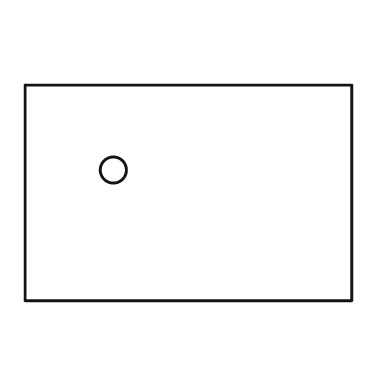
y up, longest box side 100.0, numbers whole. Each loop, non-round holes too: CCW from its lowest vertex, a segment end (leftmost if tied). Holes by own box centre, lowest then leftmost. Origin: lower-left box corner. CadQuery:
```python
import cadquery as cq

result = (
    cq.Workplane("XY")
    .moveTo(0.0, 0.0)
    .lineTo(100.0, 0.0)
    .lineTo(100.0, 66.0)
    .lineTo(0.0, 66.0)
    .close()
    .moveTo(27.0, 40.0)
    .circle(4.0)
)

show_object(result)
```